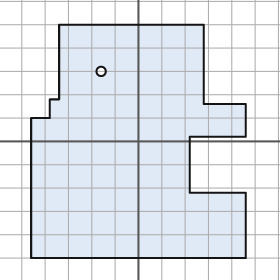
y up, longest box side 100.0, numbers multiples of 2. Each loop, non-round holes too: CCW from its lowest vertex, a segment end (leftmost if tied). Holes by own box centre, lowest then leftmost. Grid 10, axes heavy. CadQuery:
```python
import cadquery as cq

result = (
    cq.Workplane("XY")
    .moveTo(-46.0, -50.0)
    .lineTo(46.0, -50.0)
    .lineTo(46.0, -22.0)
    .lineTo(22.0, -22.0)
    .lineTo(22.0, 2.0)
    .lineTo(46.0, 2.0)
    .lineTo(46.0, 16.0)
    .lineTo(28.0, 16.0)
    .lineTo(28.0, 50.0)
    .lineTo(-34.0, 50.0)
    .lineTo(-34.0, 18.0)
    .lineTo(-38.0, 18.0)
    .lineTo(-38.0, 10.0)
    .lineTo(-46.0, 10.0)
    .close()
    .moveTo(-16.0, 30.0)
    .circle(2.0)
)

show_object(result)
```